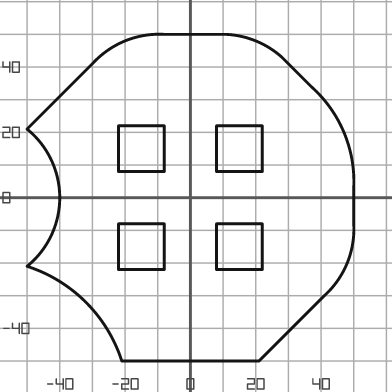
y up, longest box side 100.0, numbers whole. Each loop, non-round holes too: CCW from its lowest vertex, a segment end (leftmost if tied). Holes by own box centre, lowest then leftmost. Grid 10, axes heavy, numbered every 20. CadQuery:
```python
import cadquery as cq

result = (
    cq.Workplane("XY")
    .moveTo(-21.0, -50.0)
    .lineTo(21.0, -50.0)
    .lineTo(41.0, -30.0)
    .threePointArc((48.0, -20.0), (50.0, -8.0))
    .lineTo(50.0, 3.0)
    .threePointArc((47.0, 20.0), (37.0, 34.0))
    .lineTo(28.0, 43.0)
    .threePointArc((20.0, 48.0), (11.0, 50.0))
    .lineTo(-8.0, 50.0)
    .threePointArc((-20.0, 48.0), (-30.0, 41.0))
    .lineTo(-50.0, 21.0)
    .threePointArc((-40.0, 0.0), (-50.0, -21.0))
    .threePointArc((-32.0, -32.0), (-21.0, -50.0))
    .close()
    .moveTo(-22.0, -22.0)
    .lineTo(-8.0, -22.0)
    .lineTo(-8.0, -8.0)
    .lineTo(-22.0, -8.0)
    .close()
    .moveTo(8.0, -22.0)
    .lineTo(22.0, -22.0)
    .lineTo(22.0, -8.0)
    .lineTo(8.0, -8.0)
    .close()
    .moveTo(-22.0, 8.0)
    .lineTo(-8.0, 8.0)
    .lineTo(-8.0, 22.0)
    .lineTo(-22.0, 22.0)
    .close()
    .moveTo(8.0, 8.0)
    .lineTo(22.0, 8.0)
    .lineTo(22.0, 22.0)
    .lineTo(8.0, 22.0)
    .close()
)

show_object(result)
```